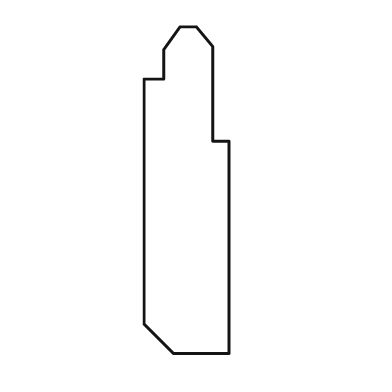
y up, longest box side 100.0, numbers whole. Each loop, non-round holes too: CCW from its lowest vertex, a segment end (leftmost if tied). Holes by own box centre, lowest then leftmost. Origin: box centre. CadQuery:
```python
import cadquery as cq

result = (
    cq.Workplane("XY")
    .moveTo(-4.0, -50.0)
    .lineTo(13.0, -50.0)
    .lineTo(13.0, 15.0)
    .lineTo(8.0, 15.0)
    .lineTo(8.0, 44.0)
    .lineTo(3.0, 50.0)
    .lineTo(-2.0, 50.0)
    .lineTo(-7.0, 43.0)
    .lineTo(-7.0, 34.0)
    .lineTo(-13.0, 34.0)
    .lineTo(-13.0, -41.0)
    .close()
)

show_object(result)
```